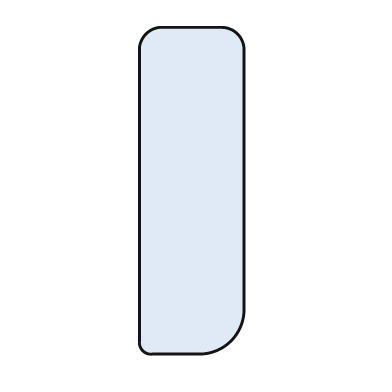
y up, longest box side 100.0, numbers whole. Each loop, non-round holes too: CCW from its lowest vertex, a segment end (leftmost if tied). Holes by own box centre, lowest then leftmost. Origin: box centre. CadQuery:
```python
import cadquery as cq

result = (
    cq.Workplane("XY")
    .moveTo(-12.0, -50.0)
    .lineTo(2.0, -50.0)
    .threePointArc((12.0, -46.0), (16.0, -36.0))
    .lineTo(16.0, 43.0)
    .threePointArc((14.0, 48.0), (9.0, 50.0))
    .lineTo(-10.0, 50.0)
    .threePointArc((-14.0, 48.0), (-16.0, 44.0))
    .lineTo(-16.0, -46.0)
    .threePointArc((-15.0, -49.0), (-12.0, -50.0))
    .close()
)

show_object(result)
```